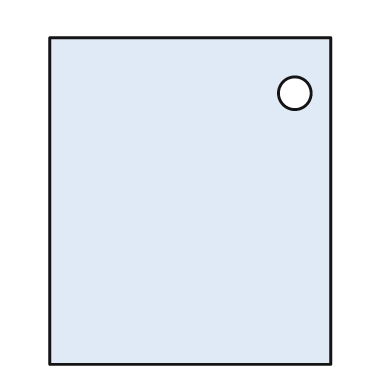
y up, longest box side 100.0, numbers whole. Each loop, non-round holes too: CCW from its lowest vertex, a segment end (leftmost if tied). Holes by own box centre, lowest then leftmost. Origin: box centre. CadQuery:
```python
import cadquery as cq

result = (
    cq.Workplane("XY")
    .moveTo(-43.0, -50.0)
    .lineTo(43.0, -50.0)
    .lineTo(43.0, 50.0)
    .lineTo(-43.0, 50.0)
    .close()
    .moveTo(32.0, 33.0)
    .circle(5.0)
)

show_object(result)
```